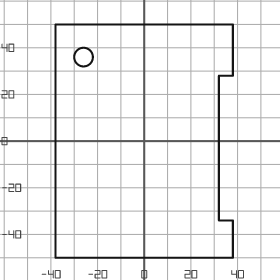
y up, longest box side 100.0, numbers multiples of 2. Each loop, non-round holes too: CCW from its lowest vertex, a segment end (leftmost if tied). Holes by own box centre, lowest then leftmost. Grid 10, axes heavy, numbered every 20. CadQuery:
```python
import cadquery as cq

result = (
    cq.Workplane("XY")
    .moveTo(-38.0, -50.0)
    .lineTo(38.0, -50.0)
    .lineTo(38.0, -34.0)
    .lineTo(32.0, -34.0)
    .lineTo(32.0, 28.0)
    .lineTo(38.0, 28.0)
    .lineTo(38.0, 50.0)
    .lineTo(-38.0, 50.0)
    .close()
    .moveTo(-26.0, 36.0)
    .circle(4.0)
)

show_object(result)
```